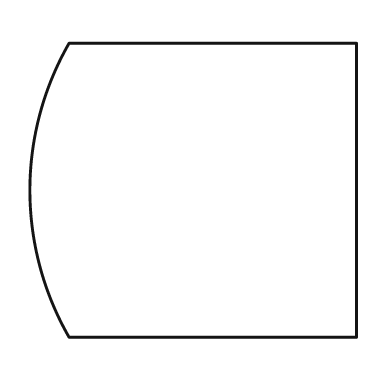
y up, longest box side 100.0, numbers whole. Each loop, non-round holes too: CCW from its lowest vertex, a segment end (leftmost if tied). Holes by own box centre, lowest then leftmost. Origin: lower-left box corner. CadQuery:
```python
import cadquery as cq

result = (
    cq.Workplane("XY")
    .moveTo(12.0, 0.0)
    .lineTo(100.0, 0.0)
    .lineTo(100.0, 90.0)
    .lineTo(12.0, 90.0)
    .threePointArc((0.0, 45.0), (12.0, 0.0))
    .close()
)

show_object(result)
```